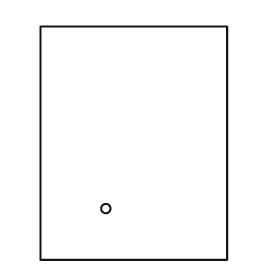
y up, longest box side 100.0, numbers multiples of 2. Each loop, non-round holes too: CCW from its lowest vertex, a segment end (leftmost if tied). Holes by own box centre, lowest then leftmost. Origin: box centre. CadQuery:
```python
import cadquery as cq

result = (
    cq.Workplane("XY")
    .moveTo(-40.0, -50.0)
    .lineTo(40.0, -50.0)
    .lineTo(40.0, 50.0)
    .lineTo(-40.0, 50.0)
    .close()
    .moveTo(-12.0, -28.0)
    .circle(2.0)
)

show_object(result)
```